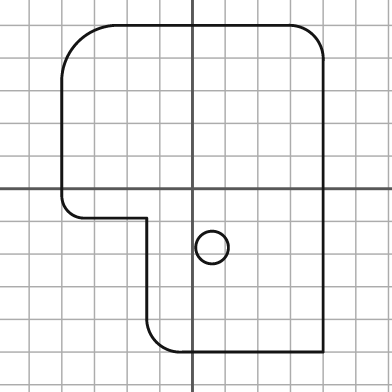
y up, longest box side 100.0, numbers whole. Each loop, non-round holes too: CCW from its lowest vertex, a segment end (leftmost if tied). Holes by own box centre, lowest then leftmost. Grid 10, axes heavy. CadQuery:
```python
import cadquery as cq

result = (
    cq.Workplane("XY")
    .moveTo(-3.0, -50.0)
    .lineTo(40.0, -50.0)
    .lineTo(40.0, 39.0)
    .threePointArc((37.0, 47.0), (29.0, 50.0))
    .lineTo(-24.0, 50.0)
    .threePointArc((-35.0, 45.0), (-40.0, 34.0))
    .lineTo(-40.0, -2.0)
    .threePointArc((-38.0, -7.0), (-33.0, -9.0))
    .lineTo(-14.0, -9.0)
    .lineTo(-14.0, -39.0)
    .threePointArc((-11.0, -47.0), (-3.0, -50.0))
    .close()
    .moveTo(6.0, -18.0)
    .circle(5.0)
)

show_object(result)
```